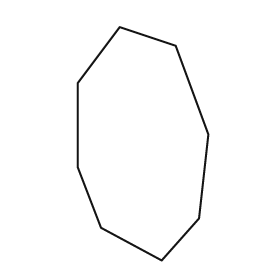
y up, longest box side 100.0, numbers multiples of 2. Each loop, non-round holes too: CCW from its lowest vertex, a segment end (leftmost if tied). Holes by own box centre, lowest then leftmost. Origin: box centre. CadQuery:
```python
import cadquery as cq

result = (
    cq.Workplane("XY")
    .moveTo(8.0, -50.0)
    .lineTo(24.0, -32.0)
    .lineTo(28.0, 4.0)
    .lineTo(14.0, 42.0)
    .lineTo(-10.0, 50.0)
    .lineTo(-28.0, 26.0)
    .lineTo(-28.0, -10.0)
    .lineTo(-18.0, -36.0)
    .close()
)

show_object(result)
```